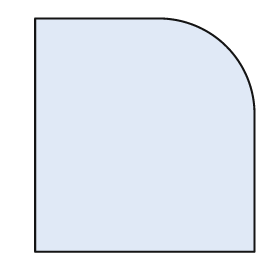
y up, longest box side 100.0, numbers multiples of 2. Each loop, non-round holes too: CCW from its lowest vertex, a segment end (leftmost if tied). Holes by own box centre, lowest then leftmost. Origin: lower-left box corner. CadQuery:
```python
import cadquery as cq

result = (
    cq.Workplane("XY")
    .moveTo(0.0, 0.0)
    .lineTo(94.0, 0.0)
    .lineTo(94.0, 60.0)
    .threePointArc((82.0, 88.0), (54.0, 100.0))
    .lineTo(0.0, 100.0)
    .close()
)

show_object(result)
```